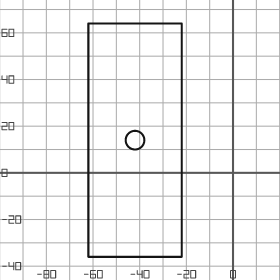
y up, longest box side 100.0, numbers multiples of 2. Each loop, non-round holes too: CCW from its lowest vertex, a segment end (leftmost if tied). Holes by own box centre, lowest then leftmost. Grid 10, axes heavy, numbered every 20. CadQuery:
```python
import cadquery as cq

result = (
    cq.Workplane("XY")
    .moveTo(-62.0, -36.0)
    .lineTo(-22.0, -36.0)
    .lineTo(-22.0, 64.0)
    .lineTo(-62.0, 64.0)
    .close()
    .moveTo(-42.0, 14.0)
    .circle(4.0)
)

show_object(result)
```